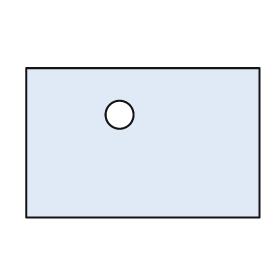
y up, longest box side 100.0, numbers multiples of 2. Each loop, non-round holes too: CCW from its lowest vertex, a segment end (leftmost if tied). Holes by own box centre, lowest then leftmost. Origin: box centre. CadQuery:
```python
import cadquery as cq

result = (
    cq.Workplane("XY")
    .moveTo(-50.0, -32.0)
    .lineTo(50.0, -32.0)
    .lineTo(50.0, 32.0)
    .lineTo(-50.0, 32.0)
    .close()
    .moveTo(-10.0, 12.0)
    .circle(6.0)
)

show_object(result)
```